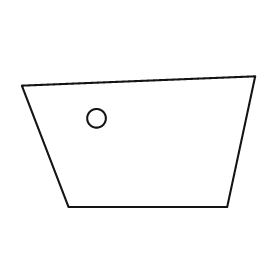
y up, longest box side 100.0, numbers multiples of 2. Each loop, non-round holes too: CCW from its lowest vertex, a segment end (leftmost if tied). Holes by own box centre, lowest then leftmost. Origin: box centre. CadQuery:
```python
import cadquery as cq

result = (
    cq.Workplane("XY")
    .moveTo(-30.0, -28.0)
    .lineTo(38.0, -28.0)
    .lineTo(50.0, 28.0)
    .lineTo(-50.0, 24.0)
    .close()
    .moveTo(-18.0, 10.0)
    .circle(4.0)
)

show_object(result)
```